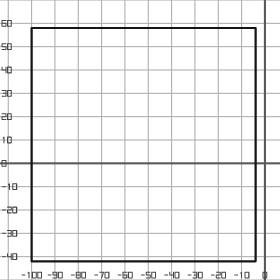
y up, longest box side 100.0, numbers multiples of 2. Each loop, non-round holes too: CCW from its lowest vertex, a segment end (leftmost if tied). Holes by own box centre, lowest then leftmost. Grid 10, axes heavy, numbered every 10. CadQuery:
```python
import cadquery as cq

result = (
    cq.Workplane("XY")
    .moveTo(-100.0, -42.0)
    .lineTo(-4.0, -42.0)
    .lineTo(-4.0, 58.0)
    .lineTo(-100.0, 58.0)
    .close()
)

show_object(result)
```